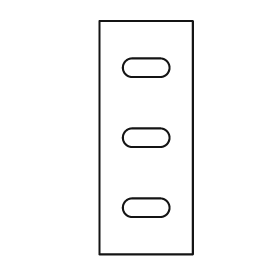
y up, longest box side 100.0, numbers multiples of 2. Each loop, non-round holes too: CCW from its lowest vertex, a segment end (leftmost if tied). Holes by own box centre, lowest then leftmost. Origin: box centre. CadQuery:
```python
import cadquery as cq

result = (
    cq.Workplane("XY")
    .moveTo(-20.0, -50.0)
    .lineTo(20.0, -50.0)
    .lineTo(20.0, 50.0)
    .lineTo(-20.0, 50.0)
    .close()
    .moveTo(-6.0, -34.0)
    .lineTo(6.0, -34.0)
    .threePointArc((10.0, -30.0), (6.0, -26.0))
    .lineTo(-6.0, -26.0)
    .threePointArc((-10.0, -30.0), (-6.0, -34.0))
    .close()
    .moveTo(-6.0, -4.0)
    .lineTo(6.0, -4.0)
    .threePointArc((10.0, 0.0), (6.0, 4.0))
    .lineTo(-6.0, 4.0)
    .threePointArc((-10.0, 0.0), (-6.0, -4.0))
    .close()
    .moveTo(-6.0, 26.0)
    .lineTo(6.0, 26.0)
    .threePointArc((10.0, 30.0), (6.0, 34.0))
    .lineTo(-6.0, 34.0)
    .threePointArc((-10.0, 30.0), (-6.0, 26.0))
    .close()
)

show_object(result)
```